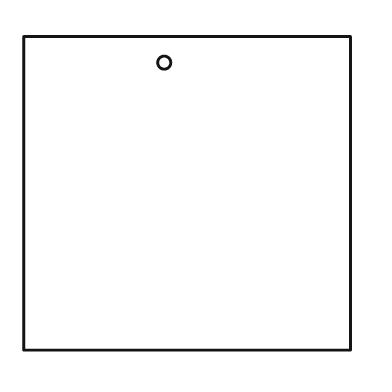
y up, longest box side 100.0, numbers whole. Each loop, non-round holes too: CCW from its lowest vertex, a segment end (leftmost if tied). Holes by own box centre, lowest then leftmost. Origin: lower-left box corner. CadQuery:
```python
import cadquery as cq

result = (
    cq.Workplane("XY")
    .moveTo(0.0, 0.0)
    .lineTo(100.0, 0.0)
    .lineTo(100.0, 96.0)
    .lineTo(0.0, 96.0)
    .close()
    .moveTo(43.0, 88.0)
    .circle(2.0)
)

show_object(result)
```